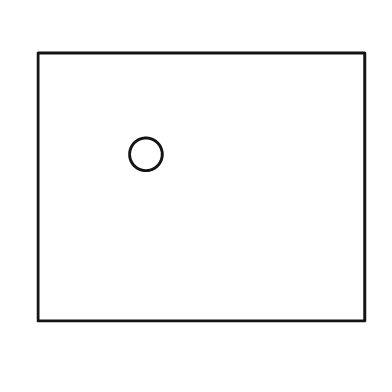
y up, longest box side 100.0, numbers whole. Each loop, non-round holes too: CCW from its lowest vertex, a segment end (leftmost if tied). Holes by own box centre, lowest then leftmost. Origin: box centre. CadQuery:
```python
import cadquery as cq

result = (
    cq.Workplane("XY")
    .moveTo(-50.0, -41.0)
    .lineTo(50.0, -41.0)
    .lineTo(50.0, 41.0)
    .lineTo(-50.0, 41.0)
    .close()
    .moveTo(-17.0, 10.0)
    .circle(5.0)
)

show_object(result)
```